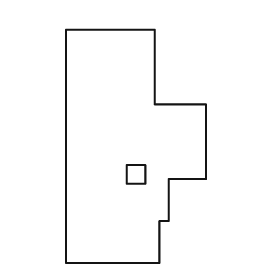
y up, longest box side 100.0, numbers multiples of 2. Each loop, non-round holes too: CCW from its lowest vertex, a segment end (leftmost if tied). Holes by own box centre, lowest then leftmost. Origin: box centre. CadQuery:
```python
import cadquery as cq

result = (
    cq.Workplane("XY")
    .moveTo(-30.0, -50.0)
    .lineTo(10.0, -50.0)
    .lineTo(10.0, -32.0)
    .lineTo(14.0, -32.0)
    .lineTo(14.0, -14.0)
    .lineTo(30.0, -14.0)
    .lineTo(30.0, 18.0)
    .lineTo(8.0, 18.0)
    .lineTo(8.0, 50.0)
    .lineTo(-30.0, 50.0)
    .close()
    .moveTo(-4.0, -16.0)
    .lineTo(4.0, -16.0)
    .lineTo(4.0, -8.0)
    .lineTo(-4.0, -8.0)
    .close()
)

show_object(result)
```